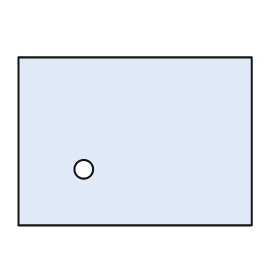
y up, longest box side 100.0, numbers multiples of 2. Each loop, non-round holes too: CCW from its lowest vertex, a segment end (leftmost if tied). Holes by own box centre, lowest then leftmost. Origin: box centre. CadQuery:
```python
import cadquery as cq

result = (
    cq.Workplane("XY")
    .moveTo(-50.0, -36.0)
    .lineTo(50.0, -36.0)
    .lineTo(50.0, 36.0)
    .lineTo(-50.0, 36.0)
    .close()
    .moveTo(-22.0, -12.0)
    .circle(4.0)
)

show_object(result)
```